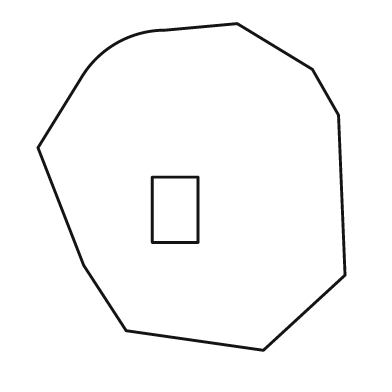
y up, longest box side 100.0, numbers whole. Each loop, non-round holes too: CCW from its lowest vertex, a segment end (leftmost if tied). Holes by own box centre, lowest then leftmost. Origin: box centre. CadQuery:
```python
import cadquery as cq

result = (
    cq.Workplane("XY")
    .moveTo(22.0, -50.0)
    .lineTo(47.0, -27.0)
    .lineTo(45.0, 22.0)
    .lineTo(37.0, 36.0)
    .lineTo(14.0, 50.0)
    .lineTo(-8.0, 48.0)
    .threePointArc((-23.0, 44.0), (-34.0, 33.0))
    .lineTo(-47.0, 12.0)
    .lineTo(-33.0, -24.0)
    .lineTo(-20.0, -44.0)
    .close()
    .moveTo(-12.0, -17.0)
    .lineTo(2.0, -17.0)
    .lineTo(2.0, 3.0)
    .lineTo(-12.0, 3.0)
    .close()
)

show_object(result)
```